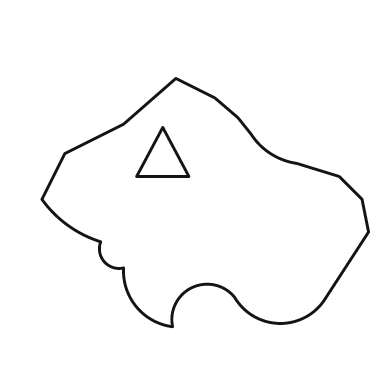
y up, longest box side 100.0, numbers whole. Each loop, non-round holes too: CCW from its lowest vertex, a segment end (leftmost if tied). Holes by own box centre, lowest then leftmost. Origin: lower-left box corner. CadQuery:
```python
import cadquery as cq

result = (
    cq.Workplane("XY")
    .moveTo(40.0, 0.0)
    .threePointArc((46.0, 12.0), (59.0, 9.0))
    .threePointArc((73.0, 1.0), (87.0, 9.0))
    .lineTo(100.0, 29.0)
    .lineTo(98.0, 39.0)
    .lineTo(91.0, 46.0)
    .lineTo(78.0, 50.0)
    .threePointArc((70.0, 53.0), (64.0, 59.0))
    .lineTo(60.0, 64.0)
    .lineTo(53.0, 70.0)
    .lineTo(41.0, 76.0)
    .lineTo(25.0, 62.0)
    .lineTo(7.0, 53.0)
    .lineTo(0.0, 39.0)
    .threePointArc((8.0, 31.0), (18.0, 26.0))
    .threePointArc((19.0, 20.0), (25.0, 18.0))
    .threePointArc((29.0, 6.0), (40.0, 0.0))
    .close()
    .moveTo(29.0, 46.0)
    .lineTo(45.0, 46.0)
    .lineTo(37.0, 61.0)
    .close()
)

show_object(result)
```